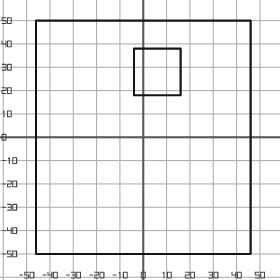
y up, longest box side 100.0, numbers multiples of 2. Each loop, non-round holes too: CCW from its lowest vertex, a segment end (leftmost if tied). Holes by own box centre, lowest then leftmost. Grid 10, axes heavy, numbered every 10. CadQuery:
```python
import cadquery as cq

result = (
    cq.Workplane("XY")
    .moveTo(-46.0, -50.0)
    .lineTo(46.0, -50.0)
    .lineTo(46.0, 50.0)
    .lineTo(-46.0, 50.0)
    .close()
    .moveTo(-4.0, 18.0)
    .lineTo(16.0, 18.0)
    .lineTo(16.0, 38.0)
    .lineTo(-4.0, 38.0)
    .close()
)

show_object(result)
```